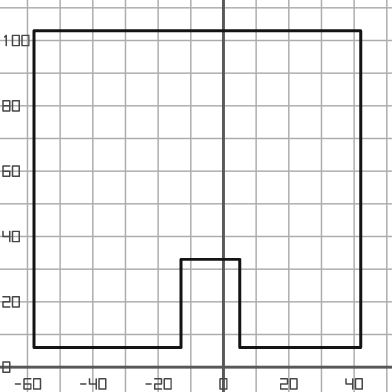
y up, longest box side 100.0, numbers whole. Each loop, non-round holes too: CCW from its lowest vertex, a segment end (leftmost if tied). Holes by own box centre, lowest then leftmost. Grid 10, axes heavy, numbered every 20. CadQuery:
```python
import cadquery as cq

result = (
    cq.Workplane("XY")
    .moveTo(-58.0, 6.0)
    .lineTo(-13.0, 6.0)
    .lineTo(-13.0, 33.0)
    .lineTo(5.0, 33.0)
    .lineTo(5.0, 6.0)
    .lineTo(42.0, 6.0)
    .lineTo(42.0, 103.0)
    .lineTo(-58.0, 103.0)
    .close()
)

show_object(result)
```